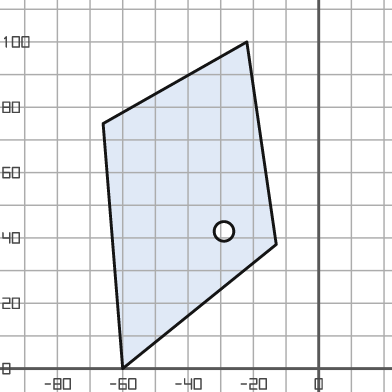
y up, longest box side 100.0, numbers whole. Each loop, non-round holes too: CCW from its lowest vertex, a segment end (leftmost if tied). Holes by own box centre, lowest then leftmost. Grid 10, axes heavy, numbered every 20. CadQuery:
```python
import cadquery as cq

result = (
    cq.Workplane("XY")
    .moveTo(-60.0, 0.0)
    .lineTo(-13.0, 38.0)
    .lineTo(-22.0, 100.0)
    .lineTo(-66.0, 75.0)
    .close()
    .moveTo(-29.0, 42.0)
    .circle(3.0)
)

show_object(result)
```